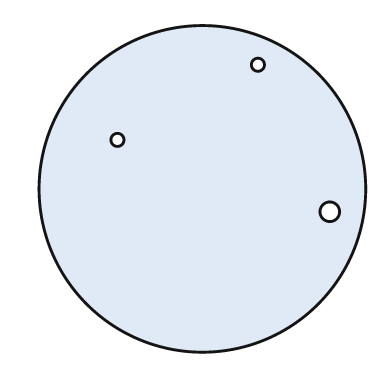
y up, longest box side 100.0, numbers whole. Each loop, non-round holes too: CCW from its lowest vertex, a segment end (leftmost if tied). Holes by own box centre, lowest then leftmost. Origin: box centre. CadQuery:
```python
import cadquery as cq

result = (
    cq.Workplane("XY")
    .moveTo(0.0, 0.0)
    .circle(50.0)
    .moveTo(39.0, -7.0)
    .circle(3.0)
    .moveTo(-26.0, 15.0)
    .circle(2.0)
    .moveTo(17.0, 38.0)
    .circle(2.0)
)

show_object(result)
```